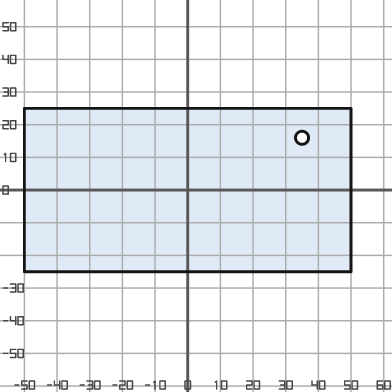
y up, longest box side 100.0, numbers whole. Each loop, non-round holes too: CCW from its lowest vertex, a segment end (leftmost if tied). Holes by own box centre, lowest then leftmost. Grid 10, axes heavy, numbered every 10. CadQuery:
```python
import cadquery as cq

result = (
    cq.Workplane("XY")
    .moveTo(-50.0, -25.0)
    .lineTo(50.0, -25.0)
    .lineTo(50.0, 25.0)
    .lineTo(-50.0, 25.0)
    .close()
    .moveTo(35.0, 16.0)
    .circle(2.0)
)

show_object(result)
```